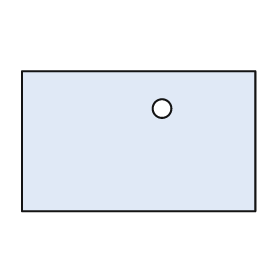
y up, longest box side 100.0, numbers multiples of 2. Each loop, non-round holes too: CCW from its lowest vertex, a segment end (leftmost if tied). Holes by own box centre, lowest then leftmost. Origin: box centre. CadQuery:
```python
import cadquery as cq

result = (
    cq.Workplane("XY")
    .moveTo(-50.0, -30.0)
    .lineTo(50.0, -30.0)
    .lineTo(50.0, 30.0)
    .lineTo(-50.0, 30.0)
    .close()
    .moveTo(10.0, 14.0)
    .circle(4.0)
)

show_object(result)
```